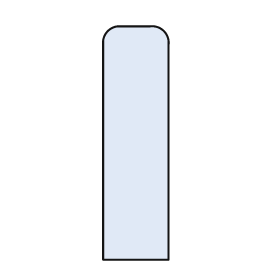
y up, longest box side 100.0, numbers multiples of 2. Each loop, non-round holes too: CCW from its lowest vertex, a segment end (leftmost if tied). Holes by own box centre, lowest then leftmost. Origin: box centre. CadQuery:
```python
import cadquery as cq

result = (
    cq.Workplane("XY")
    .moveTo(-14.0, -50.0)
    .lineTo(14.0, -50.0)
    .lineTo(14.0, 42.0)
    .threePointArc((12.0, 48.0), (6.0, 50.0))
    .lineTo(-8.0, 50.0)
    .threePointArc((-12.0, 48.0), (-14.0, 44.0))
    .close()
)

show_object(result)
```